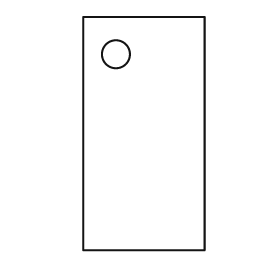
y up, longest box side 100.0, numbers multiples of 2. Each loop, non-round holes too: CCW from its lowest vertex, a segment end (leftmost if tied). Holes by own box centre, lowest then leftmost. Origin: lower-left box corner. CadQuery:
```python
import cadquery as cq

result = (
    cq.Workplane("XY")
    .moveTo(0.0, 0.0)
    .lineTo(52.0, 0.0)
    .lineTo(52.0, 100.0)
    .lineTo(0.0, 100.0)
    .close()
    .moveTo(14.0, 84.0)
    .circle(6.0)
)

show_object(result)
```